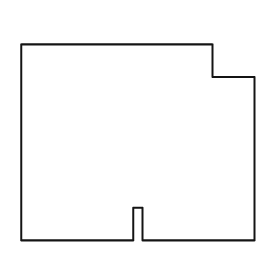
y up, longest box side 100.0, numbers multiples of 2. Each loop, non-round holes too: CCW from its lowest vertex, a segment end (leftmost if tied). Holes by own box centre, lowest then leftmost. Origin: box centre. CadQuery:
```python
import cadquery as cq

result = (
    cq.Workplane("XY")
    .moveTo(-50.0, -42.0)
    .lineTo(-2.0, -42.0)
    .lineTo(-2.0, -28.0)
    .lineTo(2.0, -28.0)
    .lineTo(2.0, -42.0)
    .lineTo(50.0, -42.0)
    .lineTo(50.0, 28.0)
    .lineTo(32.0, 28.0)
    .lineTo(32.0, 42.0)
    .lineTo(-50.0, 42.0)
    .close()
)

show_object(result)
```